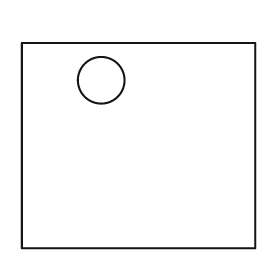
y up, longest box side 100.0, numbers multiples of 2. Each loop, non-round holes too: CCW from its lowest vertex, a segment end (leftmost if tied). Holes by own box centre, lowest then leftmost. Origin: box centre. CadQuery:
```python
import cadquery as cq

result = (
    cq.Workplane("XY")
    .moveTo(-50.0, -44.0)
    .lineTo(50.0, -44.0)
    .lineTo(50.0, 44.0)
    .lineTo(-50.0, 44.0)
    .close()
    .moveTo(-16.0, 28.0)
    .circle(10.0)
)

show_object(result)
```